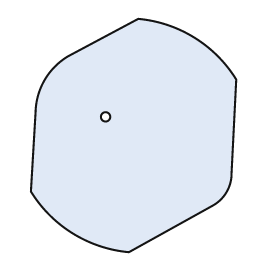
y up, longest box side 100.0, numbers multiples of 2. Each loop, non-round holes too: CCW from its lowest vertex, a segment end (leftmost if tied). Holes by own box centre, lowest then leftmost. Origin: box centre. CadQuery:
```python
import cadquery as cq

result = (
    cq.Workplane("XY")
    .moveTo(-2.0, -50.0)
    .lineTo(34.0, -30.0)
    .threePointArc((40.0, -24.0), (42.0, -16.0))
    .lineTo(44.0, 24.0)
    .threePointArc((26.0, 42.0), (2.0, 50.0))
    .lineTo(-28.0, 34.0)
    .threePointArc((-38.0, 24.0), (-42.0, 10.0))
    .lineTo(-44.0, -24.0)
    .threePointArc((-26.0, -42.0), (-2.0, -50.0))
    .close()
    .moveTo(-12.0, 8.0)
    .circle(2.0)
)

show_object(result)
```